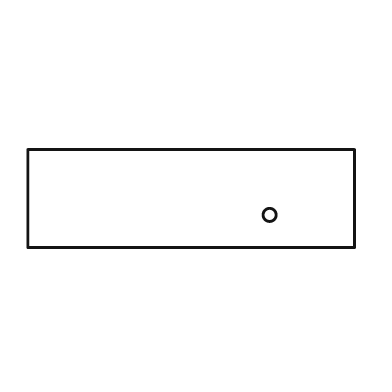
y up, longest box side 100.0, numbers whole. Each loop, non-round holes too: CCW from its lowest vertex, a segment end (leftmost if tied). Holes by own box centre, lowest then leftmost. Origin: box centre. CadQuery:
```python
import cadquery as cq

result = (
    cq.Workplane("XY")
    .moveTo(-50.0, -15.0)
    .lineTo(50.0, -15.0)
    .lineTo(50.0, 15.0)
    .lineTo(-50.0, 15.0)
    .close()
    .moveTo(24.0, -5.0)
    .circle(2.0)
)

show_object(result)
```